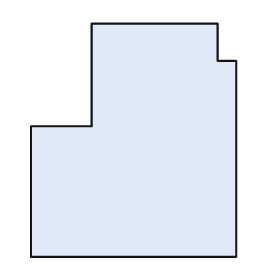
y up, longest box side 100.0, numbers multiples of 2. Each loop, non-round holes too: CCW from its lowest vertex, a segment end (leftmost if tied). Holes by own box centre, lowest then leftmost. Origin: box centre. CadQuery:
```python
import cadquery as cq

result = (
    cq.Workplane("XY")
    .moveTo(-44.0, -50.0)
    .lineTo(44.0, -50.0)
    .lineTo(44.0, 34.0)
    .lineTo(36.0, 34.0)
    .lineTo(36.0, 50.0)
    .lineTo(-18.0, 50.0)
    .lineTo(-18.0, 6.0)
    .lineTo(-44.0, 6.0)
    .close()
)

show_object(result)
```